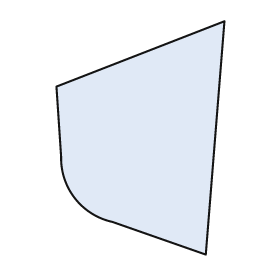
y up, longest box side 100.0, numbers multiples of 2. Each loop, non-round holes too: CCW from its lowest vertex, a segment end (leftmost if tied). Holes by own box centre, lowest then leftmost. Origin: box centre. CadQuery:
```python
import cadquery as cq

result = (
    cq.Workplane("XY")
    .moveTo(28.0, -50.0)
    .lineTo(36.0, 50.0)
    .lineTo(-36.0, 22.0)
    .lineTo(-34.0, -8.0)
    .threePointArc((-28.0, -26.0), (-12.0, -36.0))
    .close()
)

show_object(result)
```